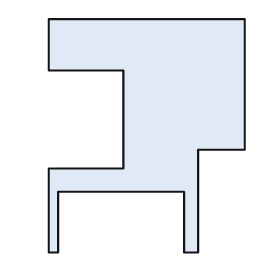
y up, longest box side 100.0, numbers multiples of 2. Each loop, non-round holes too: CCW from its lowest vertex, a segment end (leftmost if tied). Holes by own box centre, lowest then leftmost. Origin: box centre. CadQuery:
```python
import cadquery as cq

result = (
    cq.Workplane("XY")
    .moveTo(-42.0, -50.0)
    .lineTo(-38.0, -50.0)
    .lineTo(-38.0, -24.0)
    .lineTo(16.0, -24.0)
    .lineTo(16.0, -50.0)
    .lineTo(22.0, -50.0)
    .lineTo(22.0, -6.0)
    .lineTo(42.0, -6.0)
    .lineTo(42.0, 50.0)
    .lineTo(-42.0, 50.0)
    .lineTo(-42.0, 28.0)
    .lineTo(-10.0, 28.0)
    .lineTo(-10.0, -14.0)
    .lineTo(-42.0, -14.0)
    .close()
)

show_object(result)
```